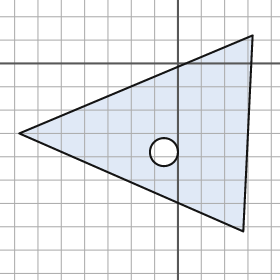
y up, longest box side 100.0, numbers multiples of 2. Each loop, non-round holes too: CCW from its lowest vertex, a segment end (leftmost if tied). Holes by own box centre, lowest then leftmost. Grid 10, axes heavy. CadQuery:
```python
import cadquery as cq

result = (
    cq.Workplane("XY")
    .moveTo(28.0, -72.0)
    .lineTo(32.0, 12.0)
    .lineTo(-68.0, -30.0)
    .close()
    .moveTo(-6.0, -38.0)
    .circle(6.0)
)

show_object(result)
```